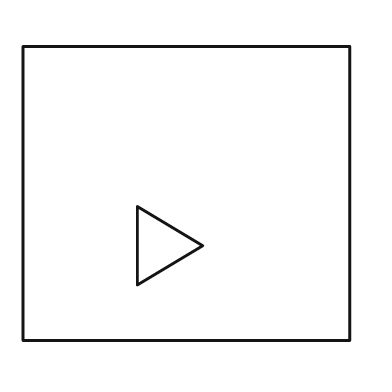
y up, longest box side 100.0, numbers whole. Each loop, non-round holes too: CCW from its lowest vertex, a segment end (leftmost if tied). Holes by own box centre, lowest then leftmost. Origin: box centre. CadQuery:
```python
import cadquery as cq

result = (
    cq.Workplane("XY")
    .moveTo(-50.0, -45.0)
    .lineTo(50.0, -45.0)
    .lineTo(50.0, 45.0)
    .lineTo(-50.0, 45.0)
    .close()
    .moveTo(-15.0, -28.0)
    .lineTo(5.0, -16.0)
    .lineTo(-15.0, -4.0)
    .close()
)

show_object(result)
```